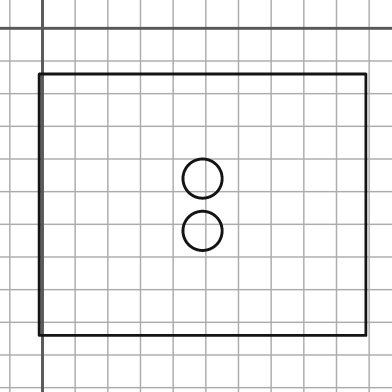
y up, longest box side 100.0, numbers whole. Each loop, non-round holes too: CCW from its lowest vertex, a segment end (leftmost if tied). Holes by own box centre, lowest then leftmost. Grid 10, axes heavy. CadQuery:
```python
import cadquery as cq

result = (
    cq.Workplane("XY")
    .moveTo(-1.0, -94.0)
    .lineTo(99.0, -94.0)
    .lineTo(99.0, -14.0)
    .lineTo(-1.0, -14.0)
    .close()
    .moveTo(49.0, -62.0)
    .circle(6.0)
    .moveTo(49.0, -46.0)
    .circle(6.0)
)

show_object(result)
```